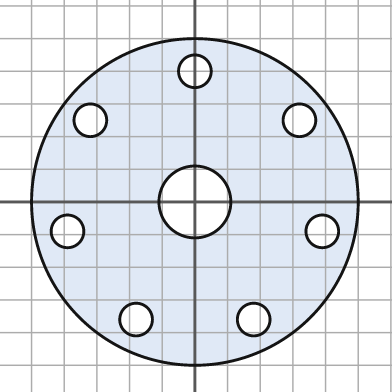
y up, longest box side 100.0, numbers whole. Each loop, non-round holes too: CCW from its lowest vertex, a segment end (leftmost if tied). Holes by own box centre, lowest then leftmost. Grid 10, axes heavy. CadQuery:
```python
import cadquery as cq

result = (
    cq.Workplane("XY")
    .moveTo(0.0, 0.0)
    .circle(50.0)
    .moveTo(-18.0, -36.0)
    .circle(5.0)
    .moveTo(18.0, -36.0)
    .circle(5.0)
    .moveTo(-39.0, -9.0)
    .circle(5.0)
    .moveTo(39.0, -9.0)
    .circle(5.0)
    .moveTo(0.0, 0.0)
    .circle(11.0)
    .moveTo(-32.0, 25.0)
    .circle(5.0)
    .moveTo(32.0, 25.0)
    .circle(5.0)
    .moveTo(0.0, 40.0)
    .circle(5.0)
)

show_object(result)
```